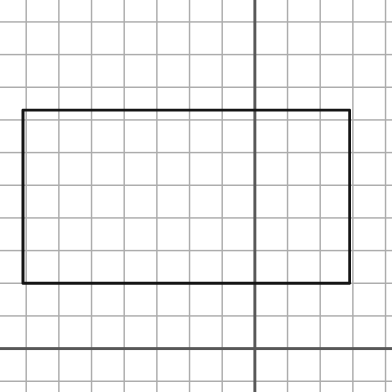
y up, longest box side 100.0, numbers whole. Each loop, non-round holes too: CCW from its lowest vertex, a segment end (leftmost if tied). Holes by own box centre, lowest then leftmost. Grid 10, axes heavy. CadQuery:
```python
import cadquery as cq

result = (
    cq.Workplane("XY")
    .moveTo(-71.0, 20.0)
    .lineTo(29.0, 20.0)
    .lineTo(29.0, 73.0)
    .lineTo(-71.0, 73.0)
    .close()
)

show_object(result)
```